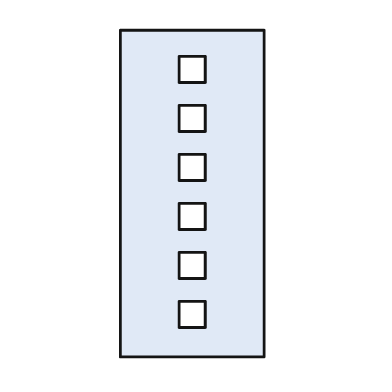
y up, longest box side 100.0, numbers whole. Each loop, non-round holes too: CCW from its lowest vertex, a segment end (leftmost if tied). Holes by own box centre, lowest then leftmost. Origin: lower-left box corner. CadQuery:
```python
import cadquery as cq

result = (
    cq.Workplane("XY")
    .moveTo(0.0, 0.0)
    .lineTo(44.0, 0.0)
    .lineTo(44.0, 100.0)
    .lineTo(0.0, 100.0)
    .close()
    .moveTo(18.0, 9.0)
    .lineTo(26.0, 9.0)
    .lineTo(26.0, 17.0)
    .lineTo(18.0, 17.0)
    .close()
    .moveTo(18.0, 24.0)
    .lineTo(26.0, 24.0)
    .lineTo(26.0, 32.0)
    .lineTo(18.0, 32.0)
    .close()
    .moveTo(18.0, 39.0)
    .lineTo(26.0, 39.0)
    .lineTo(26.0, 47.0)
    .lineTo(18.0, 47.0)
    .close()
    .moveTo(18.0, 54.0)
    .lineTo(26.0, 54.0)
    .lineTo(26.0, 62.0)
    .lineTo(18.0, 62.0)
    .close()
    .moveTo(18.0, 69.0)
    .lineTo(26.0, 69.0)
    .lineTo(26.0, 77.0)
    .lineTo(18.0, 77.0)
    .close()
    .moveTo(18.0, 84.0)
    .lineTo(26.0, 84.0)
    .lineTo(26.0, 92.0)
    .lineTo(18.0, 92.0)
    .close()
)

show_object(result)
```